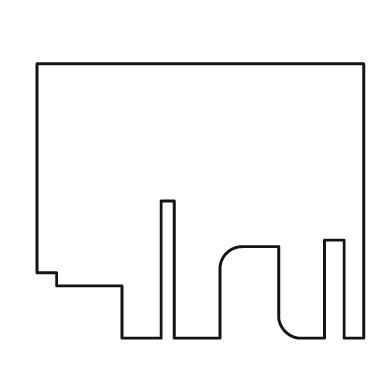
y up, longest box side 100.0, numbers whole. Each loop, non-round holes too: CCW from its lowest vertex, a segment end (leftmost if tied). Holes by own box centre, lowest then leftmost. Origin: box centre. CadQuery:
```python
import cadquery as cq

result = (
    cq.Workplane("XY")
    .moveTo(-24.0, -42.0)
    .lineTo(-12.0, -42.0)
    .lineTo(-12.0, 0.0)
    .lineTo(-8.0, 0.0)
    .lineTo(-8.0, -42.0)
    .lineTo(6.0, -42.0)
    .lineTo(6.0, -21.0)
    .threePointArc((8.0, -16.0), (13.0, -14.0))
    .lineTo(24.0, -14.0)
    .lineTo(24.0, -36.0)
    .threePointArc((26.0, -40.0), (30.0, -42.0))
    .lineTo(38.0, -42.0)
    .lineTo(38.0, -12.0)
    .lineTo(44.0, -12.0)
    .lineTo(44.0, -42.0)
    .lineTo(50.0, -42.0)
    .lineTo(50.0, 42.0)
    .lineTo(-50.0, 42.0)
    .lineTo(-50.0, -22.0)
    .lineTo(-44.0, -22.0)
    .lineTo(-44.0, -26.0)
    .lineTo(-24.0, -26.0)
    .close()
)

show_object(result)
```